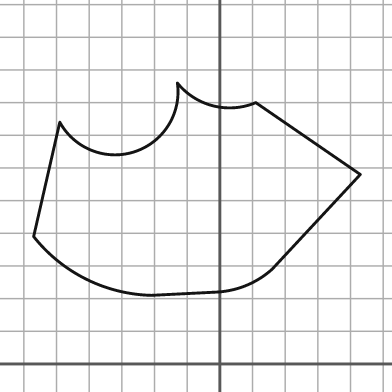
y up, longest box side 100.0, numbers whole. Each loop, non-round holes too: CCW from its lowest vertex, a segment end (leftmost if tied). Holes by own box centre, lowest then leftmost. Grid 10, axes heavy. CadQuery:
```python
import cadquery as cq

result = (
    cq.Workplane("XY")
    .moveTo(-21.0, 21.0)
    .lineTo(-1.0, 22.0)
    .threePointArc((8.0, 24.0), (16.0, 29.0))
    .lineTo(43.0, 58.0)
    .lineTo(11.0, 80.0)
    .threePointArc((-2.0, 79.0), (-13.0, 86.0))
    .threePointArc((-26.0, 65.0), (-49.0, 74.0))
    .lineTo(-57.0, 39.0)
    .threePointArc((-41.0, 26.0), (-21.0, 21.0))
    .close()
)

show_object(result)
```